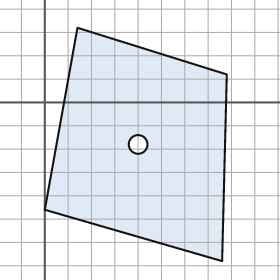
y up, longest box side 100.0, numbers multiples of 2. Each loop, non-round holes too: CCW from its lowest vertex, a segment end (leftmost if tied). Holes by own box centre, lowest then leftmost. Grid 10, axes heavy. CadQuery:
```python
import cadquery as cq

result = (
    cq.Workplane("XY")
    .moveTo(76.0, -68.0)
    .lineTo(78.0, 12.0)
    .lineTo(14.0, 32.0)
    .lineTo(0.0, -46.0)
    .close()
    .moveTo(40.0, -18.0)
    .circle(4.0)
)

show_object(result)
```